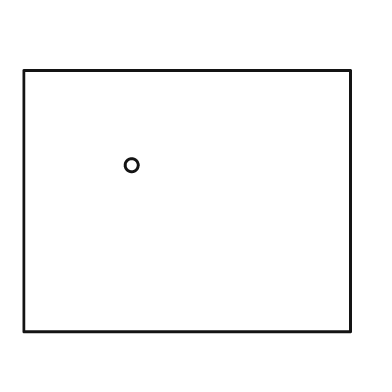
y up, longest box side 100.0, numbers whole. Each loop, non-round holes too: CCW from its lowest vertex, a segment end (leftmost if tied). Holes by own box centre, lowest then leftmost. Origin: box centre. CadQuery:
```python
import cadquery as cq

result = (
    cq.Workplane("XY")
    .moveTo(-50.0, -40.0)
    .lineTo(50.0, -40.0)
    .lineTo(50.0, 40.0)
    .lineTo(-50.0, 40.0)
    .close()
    .moveTo(-17.0, 11.0)
    .circle(2.0)
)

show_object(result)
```